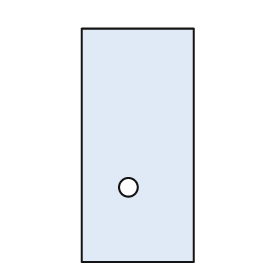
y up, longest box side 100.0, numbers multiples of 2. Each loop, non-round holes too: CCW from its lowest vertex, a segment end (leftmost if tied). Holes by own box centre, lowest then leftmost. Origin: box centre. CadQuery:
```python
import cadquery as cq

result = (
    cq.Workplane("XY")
    .moveTo(-24.0, -50.0)
    .lineTo(24.0, -50.0)
    .lineTo(24.0, 50.0)
    .lineTo(-24.0, 50.0)
    .close()
    .moveTo(-4.0, -18.0)
    .circle(4.0)
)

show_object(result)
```